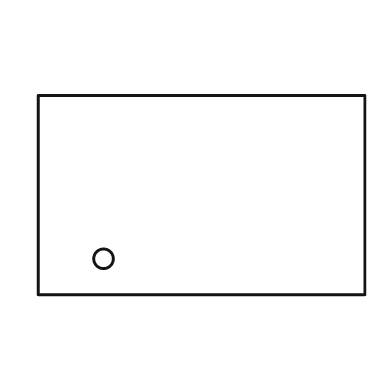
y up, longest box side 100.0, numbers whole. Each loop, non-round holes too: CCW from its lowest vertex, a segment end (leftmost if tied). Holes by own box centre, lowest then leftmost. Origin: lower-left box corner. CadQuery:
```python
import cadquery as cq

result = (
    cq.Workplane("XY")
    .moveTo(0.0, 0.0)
    .lineTo(100.0, 0.0)
    .lineTo(100.0, 61.0)
    .lineTo(0.0, 61.0)
    .close()
    .moveTo(20.0, 11.0)
    .circle(3.0)
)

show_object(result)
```